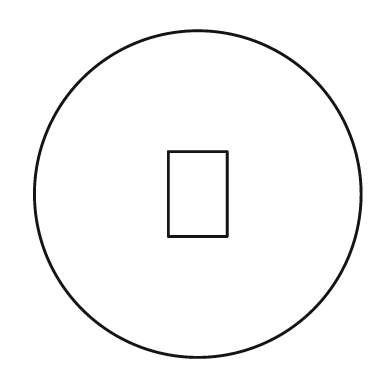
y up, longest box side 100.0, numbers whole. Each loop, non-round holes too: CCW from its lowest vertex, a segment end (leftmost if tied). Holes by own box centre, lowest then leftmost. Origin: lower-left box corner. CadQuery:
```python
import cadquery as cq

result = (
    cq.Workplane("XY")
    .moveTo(50.0, 50.0)
    .circle(50.0)
    .moveTo(41.0, 37.0)
    .lineTo(59.0, 37.0)
    .lineTo(59.0, 63.0)
    .lineTo(41.0, 63.0)
    .close()
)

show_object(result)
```